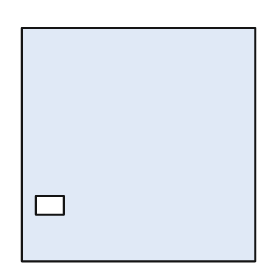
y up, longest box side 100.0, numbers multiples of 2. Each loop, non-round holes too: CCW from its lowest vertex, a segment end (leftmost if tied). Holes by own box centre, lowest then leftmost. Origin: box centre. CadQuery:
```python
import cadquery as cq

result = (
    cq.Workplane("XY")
    .moveTo(-50.0, -50.0)
    .lineTo(50.0, -50.0)
    .lineTo(50.0, 50.0)
    .lineTo(-50.0, 50.0)
    .close()
    .moveTo(-44.0, -30.0)
    .lineTo(-32.0, -30.0)
    .lineTo(-32.0, -22.0)
    .lineTo(-44.0, -22.0)
    .close()
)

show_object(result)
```